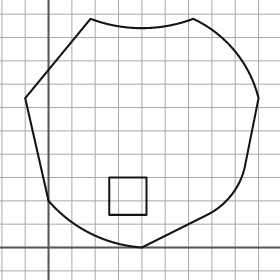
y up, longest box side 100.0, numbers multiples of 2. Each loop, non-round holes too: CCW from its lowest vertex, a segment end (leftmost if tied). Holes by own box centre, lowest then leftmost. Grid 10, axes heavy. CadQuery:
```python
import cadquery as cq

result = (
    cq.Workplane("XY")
    .moveTo(40.0, 0.0)
    .lineTo(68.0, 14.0)
    .threePointArc((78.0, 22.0), (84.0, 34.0))
    .lineTo(90.0, 64.0)
    .threePointArc((80.0, 84.0), (62.0, 98.0))
    .threePointArc((40.0, 94.0), (18.0, 98.0))
    .lineTo(-10.0, 64.0)
    .lineTo(0.0, 20.0)
    .threePointArc((18.0, 6.0), (40.0, 0.0))
    .close()
    .moveTo(26.0, 14.0)
    .lineTo(42.0, 14.0)
    .lineTo(42.0, 30.0)
    .lineTo(26.0, 30.0)
    .close()
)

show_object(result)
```